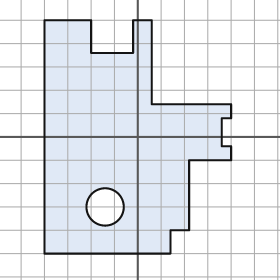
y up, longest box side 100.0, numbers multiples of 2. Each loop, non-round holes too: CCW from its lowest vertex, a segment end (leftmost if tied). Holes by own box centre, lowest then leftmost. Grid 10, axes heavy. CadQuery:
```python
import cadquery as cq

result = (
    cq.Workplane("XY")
    .moveTo(-40.0, -50.0)
    .lineTo(14.0, -50.0)
    .lineTo(14.0, -40.0)
    .lineTo(22.0, -40.0)
    .lineTo(22.0, -10.0)
    .lineTo(40.0, -10.0)
    .lineTo(40.0, -4.0)
    .lineTo(36.0, -4.0)
    .lineTo(36.0, 8.0)
    .lineTo(40.0, 8.0)
    .lineTo(40.0, 14.0)
    .lineTo(6.0, 14.0)
    .lineTo(6.0, 50.0)
    .lineTo(-2.0, 50.0)
    .lineTo(-2.0, 36.0)
    .lineTo(-20.0, 36.0)
    .lineTo(-20.0, 50.0)
    .lineTo(-40.0, 50.0)
    .close()
    .moveTo(-14.0, -30.0)
    .circle(8.0)
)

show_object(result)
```